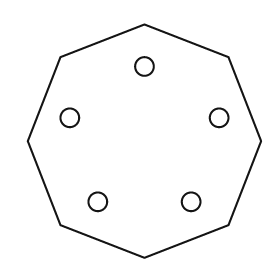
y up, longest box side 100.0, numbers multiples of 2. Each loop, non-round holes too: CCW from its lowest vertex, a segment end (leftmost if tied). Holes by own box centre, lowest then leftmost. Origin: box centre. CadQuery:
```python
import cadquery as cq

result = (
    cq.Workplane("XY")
    .moveTo(0.0, -50.0)
    .lineTo(36.0, -36.0)
    .lineTo(50.0, 0.0)
    .lineTo(36.0, 36.0)
    .lineTo(0.0, 50.0)
    .lineTo(-36.0, 36.0)
    .lineTo(-50.0, 0.0)
    .lineTo(-36.0, -36.0)
    .close()
    .moveTo(-20.0, -26.0)
    .circle(4.0)
    .moveTo(20.0, -26.0)
    .circle(4.0)
    .moveTo(-32.0, 10.0)
    .circle(4.0)
    .moveTo(32.0, 10.0)
    .circle(4.0)
    .moveTo(0.0, 32.0)
    .circle(4.0)
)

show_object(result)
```